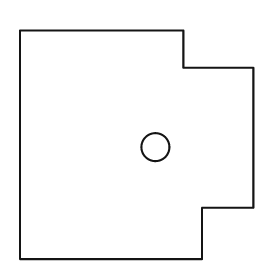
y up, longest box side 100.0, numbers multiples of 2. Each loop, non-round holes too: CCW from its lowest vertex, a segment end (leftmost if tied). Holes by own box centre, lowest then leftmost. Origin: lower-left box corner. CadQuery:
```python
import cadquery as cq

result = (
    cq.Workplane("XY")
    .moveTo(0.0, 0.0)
    .lineTo(78.0, 0.0)
    .lineTo(78.0, 22.0)
    .lineTo(100.0, 22.0)
    .lineTo(100.0, 82.0)
    .lineTo(70.0, 82.0)
    .lineTo(70.0, 98.0)
    .lineTo(0.0, 98.0)
    .close()
    .moveTo(58.0, 48.0)
    .circle(6.0)
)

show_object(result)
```